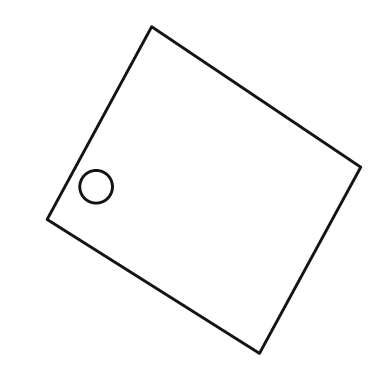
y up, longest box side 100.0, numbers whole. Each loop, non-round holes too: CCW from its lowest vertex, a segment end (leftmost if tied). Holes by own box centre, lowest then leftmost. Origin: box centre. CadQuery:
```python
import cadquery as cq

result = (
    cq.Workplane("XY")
    .moveTo(17.0, -50.0)
    .lineTo(48.0, 7.0)
    .lineTo(-16.0, 50.0)
    .lineTo(-48.0, -9.0)
    .close()
    .moveTo(-33.0, 1.0)
    .circle(5.0)
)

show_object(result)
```